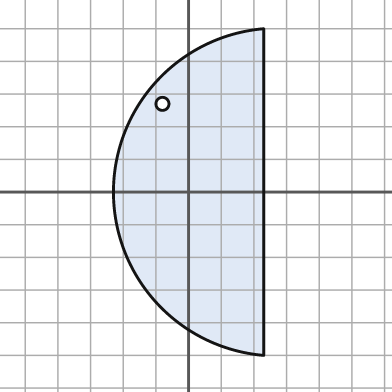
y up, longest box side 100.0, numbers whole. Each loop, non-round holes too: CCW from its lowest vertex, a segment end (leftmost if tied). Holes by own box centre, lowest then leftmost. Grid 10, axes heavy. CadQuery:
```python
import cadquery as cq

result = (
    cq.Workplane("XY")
    .moveTo(23.0, -50.0)
    .lineTo(23.0, 50.0)
    .threePointArc((-23.0, 0.0), (23.0, -50.0))
    .close()
    .moveTo(-8.0, 27.0)
    .circle(2.0)
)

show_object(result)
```